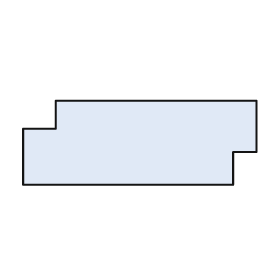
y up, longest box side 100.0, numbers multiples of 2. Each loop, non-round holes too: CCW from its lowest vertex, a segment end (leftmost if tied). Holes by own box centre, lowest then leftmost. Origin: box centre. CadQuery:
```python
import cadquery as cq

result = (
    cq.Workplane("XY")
    .moveTo(-50.0, -18.0)
    .lineTo(40.0, -18.0)
    .lineTo(40.0, -4.0)
    .lineTo(50.0, -4.0)
    .lineTo(50.0, 18.0)
    .lineTo(-36.0, 18.0)
    .lineTo(-36.0, 6.0)
    .lineTo(-50.0, 6.0)
    .close()
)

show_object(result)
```